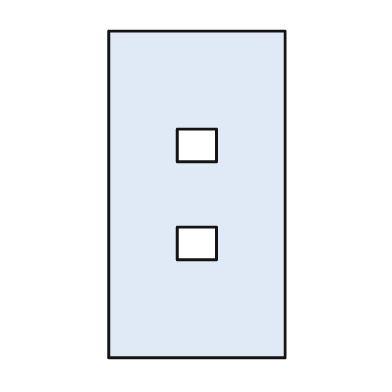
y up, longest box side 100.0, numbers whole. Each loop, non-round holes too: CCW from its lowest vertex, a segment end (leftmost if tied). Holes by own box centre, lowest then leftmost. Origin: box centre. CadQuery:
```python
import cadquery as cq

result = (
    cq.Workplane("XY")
    .moveTo(-27.0, -50.0)
    .lineTo(27.0, -50.0)
    .lineTo(27.0, 50.0)
    .lineTo(-27.0, 50.0)
    .close()
    .moveTo(-6.0, -20.0)
    .lineTo(6.0, -20.0)
    .lineTo(6.0, -10.0)
    .lineTo(-6.0, -10.0)
    .close()
    .moveTo(-6.0, 10.0)
    .lineTo(6.0, 10.0)
    .lineTo(6.0, 20.0)
    .lineTo(-6.0, 20.0)
    .close()
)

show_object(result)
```